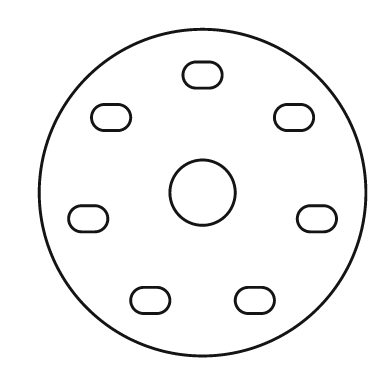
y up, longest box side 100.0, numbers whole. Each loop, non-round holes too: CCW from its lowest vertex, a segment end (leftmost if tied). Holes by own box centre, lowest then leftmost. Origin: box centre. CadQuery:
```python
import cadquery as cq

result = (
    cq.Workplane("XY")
    .moveTo(0.0, 0.0)
    .circle(50.0)
    .moveTo(-18.0, -37.0)
    .lineTo(-14.0, -37.0)
    .threePointArc((-10.0, -33.0), (-14.0, -29.0))
    .lineTo(-18.0, -29.0)
    .threePointArc((-22.0, -33.0), (-18.0, -37.0))
    .close()
    .moveTo(14.0, -37.0)
    .lineTo(18.0, -37.0)
    .threePointArc((22.0, -33.0), (18.0, -29.0))
    .lineTo(14.0, -29.0)
    .threePointArc((10.0, -33.0), (14.0, -37.0))
    .close()
    .moveTo(-37.0, -12.0)
    .lineTo(-33.0, -12.0)
    .threePointArc((-29.0, -8.0), (-33.0, -4.0))
    .lineTo(-37.0, -4.0)
    .threePointArc((-41.0, -8.0), (-37.0, -12.0))
    .close()
    .moveTo(33.0, -12.0)
    .lineTo(37.0, -12.0)
    .threePointArc((41.0, -8.0), (37.0, -4.0))
    .lineTo(33.0, -4.0)
    .threePointArc((29.0, -8.0), (33.0, -12.0))
    .close()
    .moveTo(0.0, 0.0)
    .circle(10.0)
    .moveTo(-30.0, 19.0)
    .lineTo(-26.0, 19.0)
    .threePointArc((-22.0, 23.0), (-26.0, 27.0))
    .lineTo(-30.0, 27.0)
    .threePointArc((-34.0, 23.0), (-30.0, 19.0))
    .close()
    .moveTo(26.0, 19.0)
    .lineTo(30.0, 19.0)
    .threePointArc((34.0, 23.0), (30.0, 27.0))
    .lineTo(26.0, 27.0)
    .threePointArc((22.0, 23.0), (26.0, 19.0))
    .close()
    .moveTo(-2.0, 32.0)
    .lineTo(2.0, 32.0)
    .threePointArc((6.0, 36.0), (2.0, 40.0))
    .lineTo(-2.0, 40.0)
    .threePointArc((-6.0, 36.0), (-2.0, 32.0))
    .close()
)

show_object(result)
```